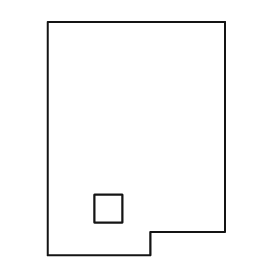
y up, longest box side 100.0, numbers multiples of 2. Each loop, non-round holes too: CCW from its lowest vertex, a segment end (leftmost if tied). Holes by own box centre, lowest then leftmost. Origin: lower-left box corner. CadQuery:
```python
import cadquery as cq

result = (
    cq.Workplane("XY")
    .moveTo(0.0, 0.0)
    .lineTo(44.0, 0.0)
    .lineTo(44.0, 10.0)
    .lineTo(76.0, 10.0)
    .lineTo(76.0, 100.0)
    .lineTo(0.0, 100.0)
    .close()
    .moveTo(20.0, 14.0)
    .lineTo(32.0, 14.0)
    .lineTo(32.0, 26.0)
    .lineTo(20.0, 26.0)
    .close()
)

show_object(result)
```